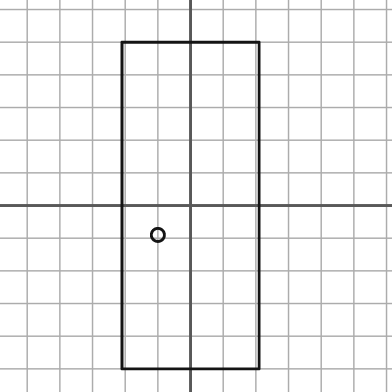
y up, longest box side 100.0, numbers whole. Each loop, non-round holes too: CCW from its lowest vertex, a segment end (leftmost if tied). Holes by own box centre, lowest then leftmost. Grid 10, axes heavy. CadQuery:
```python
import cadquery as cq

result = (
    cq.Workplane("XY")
    .moveTo(-21.0, -50.0)
    .lineTo(21.0, -50.0)
    .lineTo(21.0, 50.0)
    .lineTo(-21.0, 50.0)
    .close()
    .moveTo(-10.0, -9.0)
    .circle(2.0)
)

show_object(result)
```